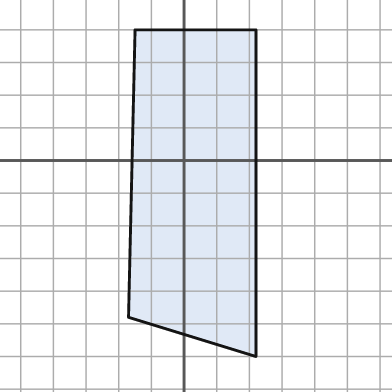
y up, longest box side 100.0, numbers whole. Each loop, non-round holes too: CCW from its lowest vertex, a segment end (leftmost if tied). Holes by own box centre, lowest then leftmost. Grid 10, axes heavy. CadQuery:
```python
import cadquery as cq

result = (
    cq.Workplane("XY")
    .moveTo(22.0, -60.0)
    .lineTo(22.0, 40.0)
    .lineTo(-15.0, 40.0)
    .lineTo(-17.0, -48.0)
    .close()
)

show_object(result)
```